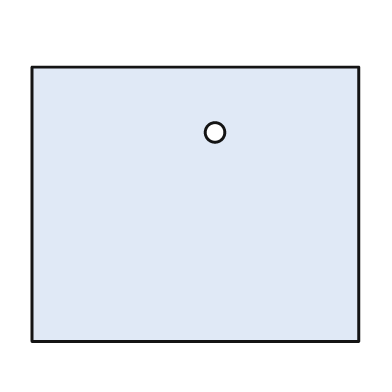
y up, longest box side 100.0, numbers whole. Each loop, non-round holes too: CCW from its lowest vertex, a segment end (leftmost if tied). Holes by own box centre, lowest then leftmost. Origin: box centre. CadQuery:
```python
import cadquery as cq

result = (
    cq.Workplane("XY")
    .moveTo(-50.0, -42.0)
    .lineTo(50.0, -42.0)
    .lineTo(50.0, 42.0)
    .lineTo(-50.0, 42.0)
    .close()
    .moveTo(6.0, 22.0)
    .circle(3.0)
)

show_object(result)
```